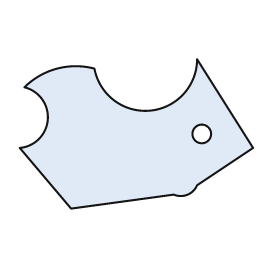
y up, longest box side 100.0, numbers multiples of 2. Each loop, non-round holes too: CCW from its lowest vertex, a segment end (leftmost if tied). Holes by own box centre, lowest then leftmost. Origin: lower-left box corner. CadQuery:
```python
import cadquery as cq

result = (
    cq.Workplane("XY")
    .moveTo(22.0, 0.0)
    .lineTo(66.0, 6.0)
    .threePointArc((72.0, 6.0), (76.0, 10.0))
    .lineTo(100.0, 26.0)
    .lineTo(76.0, 64.0)
    .threePointArc((56.0, 42.0), (32.0, 60.0))
    .threePointArc((16.0, 60.0), (2.0, 52.0))
    .threePointArc((12.0, 38.0), (0.0, 26.0))
    .close()
    .moveTo(78.0, 32.0)
    .circle(4.0)
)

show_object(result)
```